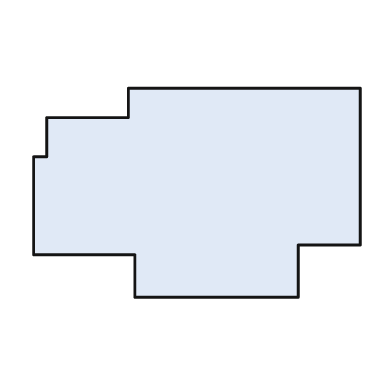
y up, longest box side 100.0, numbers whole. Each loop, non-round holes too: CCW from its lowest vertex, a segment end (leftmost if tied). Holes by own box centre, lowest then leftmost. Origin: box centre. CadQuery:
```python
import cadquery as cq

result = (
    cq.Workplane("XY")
    .moveTo(-19.0, -32.0)
    .lineTo(31.0, -32.0)
    .lineTo(31.0, -16.0)
    .lineTo(50.0, -16.0)
    .lineTo(50.0, 32.0)
    .lineTo(-21.0, 32.0)
    .lineTo(-21.0, 23.0)
    .lineTo(-46.0, 23.0)
    .lineTo(-46.0, 11.0)
    .lineTo(-50.0, 11.0)
    .lineTo(-50.0, -19.0)
    .lineTo(-19.0, -19.0)
    .close()
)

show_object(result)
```